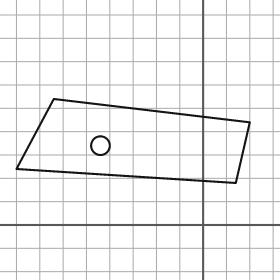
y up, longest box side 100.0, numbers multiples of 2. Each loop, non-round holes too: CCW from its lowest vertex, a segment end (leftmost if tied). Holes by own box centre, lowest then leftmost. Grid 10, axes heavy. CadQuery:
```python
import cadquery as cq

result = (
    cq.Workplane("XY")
    .moveTo(14.0, 18.0)
    .lineTo(20.0, 44.0)
    .lineTo(-64.0, 54.0)
    .lineTo(-80.0, 24.0)
    .close()
    .moveTo(-44.0, 34.0)
    .circle(4.0)
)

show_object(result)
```